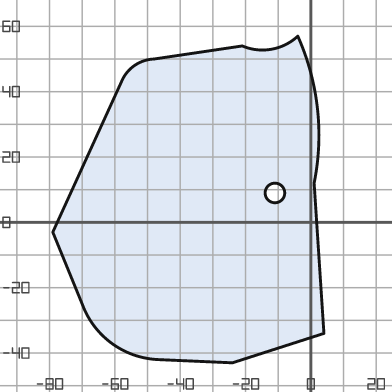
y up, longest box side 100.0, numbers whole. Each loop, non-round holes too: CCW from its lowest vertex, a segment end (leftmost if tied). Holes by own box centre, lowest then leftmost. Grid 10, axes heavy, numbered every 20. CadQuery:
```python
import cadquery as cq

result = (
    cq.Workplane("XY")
    .moveTo(-24.0, -43.0)
    .lineTo(4.0, -34.0)
    .lineTo(1.0, 12.0)
    .threePointArc((2.0, 35.0), (-4.0, 57.0))
    .threePointArc((-12.0, 53.0), (-21.0, 54.0))
    .lineTo(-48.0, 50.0)
    .threePointArc((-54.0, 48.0), (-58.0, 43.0))
    .lineTo(-79.0, -3.0)
    .lineTo(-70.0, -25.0)
    .threePointArc((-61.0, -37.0), (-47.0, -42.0))
    .close()
    .moveTo(-11.0, 9.0)
    .circle(3.0)
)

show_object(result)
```